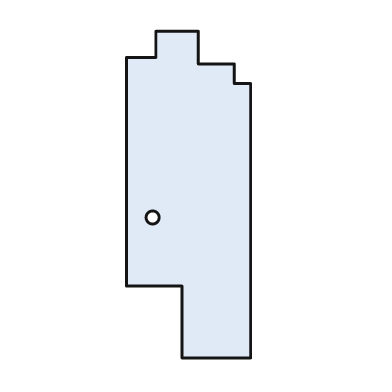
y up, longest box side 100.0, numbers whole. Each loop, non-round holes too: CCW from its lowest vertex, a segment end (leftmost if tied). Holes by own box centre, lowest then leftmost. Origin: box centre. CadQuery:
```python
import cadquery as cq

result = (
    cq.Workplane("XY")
    .moveTo(-2.0, -50.0)
    .lineTo(19.0, -50.0)
    .lineTo(19.0, 34.0)
    .lineTo(14.0, 34.0)
    .lineTo(14.0, 40.0)
    .lineTo(3.0, 40.0)
    .lineTo(3.0, 50.0)
    .lineTo(-10.0, 50.0)
    .lineTo(-10.0, 42.0)
    .lineTo(-19.0, 42.0)
    .lineTo(-19.0, -28.0)
    .lineTo(-2.0, -28.0)
    .close()
    .moveTo(-11.0, -7.0)
    .circle(2.0)
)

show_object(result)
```